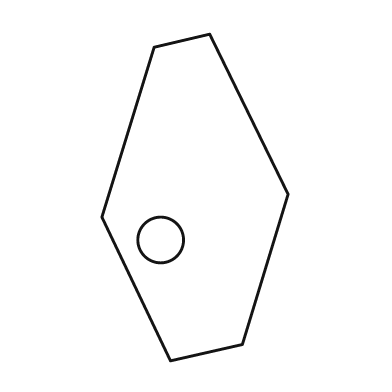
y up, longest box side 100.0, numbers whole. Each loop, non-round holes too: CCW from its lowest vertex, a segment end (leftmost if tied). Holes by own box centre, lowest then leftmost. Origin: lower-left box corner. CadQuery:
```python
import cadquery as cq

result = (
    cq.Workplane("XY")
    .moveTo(21.0, 0.0)
    .lineTo(43.0, 5.0)
    .lineTo(57.0, 51.0)
    .lineTo(33.0, 100.0)
    .lineTo(16.0, 96.0)
    .lineTo(0.0, 44.0)
    .close()
    .moveTo(18.0, 37.0)
    .circle(7.0)
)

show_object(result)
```